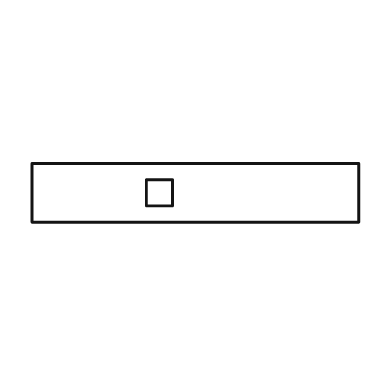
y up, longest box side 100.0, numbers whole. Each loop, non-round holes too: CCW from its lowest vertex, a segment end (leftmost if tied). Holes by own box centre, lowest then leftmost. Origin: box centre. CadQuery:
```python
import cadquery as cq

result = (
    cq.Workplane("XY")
    .moveTo(-50.0, -9.0)
    .lineTo(50.0, -9.0)
    .lineTo(50.0, 9.0)
    .lineTo(-50.0, 9.0)
    .close()
    .moveTo(-15.0, -4.0)
    .lineTo(-7.0, -4.0)
    .lineTo(-7.0, 4.0)
    .lineTo(-15.0, 4.0)
    .close()
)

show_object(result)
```